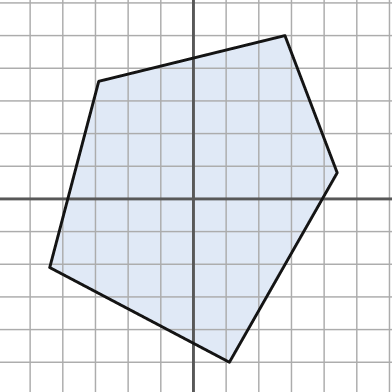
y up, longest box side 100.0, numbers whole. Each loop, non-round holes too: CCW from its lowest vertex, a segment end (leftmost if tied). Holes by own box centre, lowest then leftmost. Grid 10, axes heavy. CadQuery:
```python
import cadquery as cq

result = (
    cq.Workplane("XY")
    .moveTo(11.0, -50.0)
    .lineTo(44.0, 8.0)
    .lineTo(28.0, 50.0)
    .lineTo(-29.0, 36.0)
    .lineTo(-44.0, -21.0)
    .close()
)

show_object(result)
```